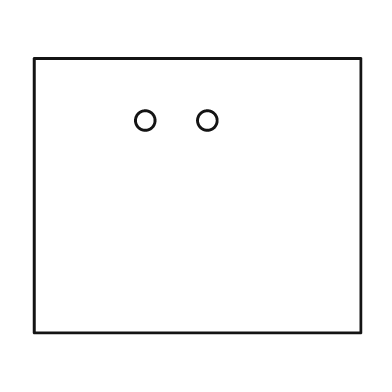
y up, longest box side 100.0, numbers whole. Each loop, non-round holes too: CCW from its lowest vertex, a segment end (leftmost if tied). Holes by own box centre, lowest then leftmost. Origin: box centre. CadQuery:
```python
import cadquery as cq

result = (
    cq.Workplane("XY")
    .moveTo(-50.0, -42.0)
    .lineTo(50.0, -42.0)
    .lineTo(50.0, 42.0)
    .lineTo(-50.0, 42.0)
    .close()
    .moveTo(-16.0, 23.0)
    .circle(3.0)
    .moveTo(3.0, 23.0)
    .circle(3.0)
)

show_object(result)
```